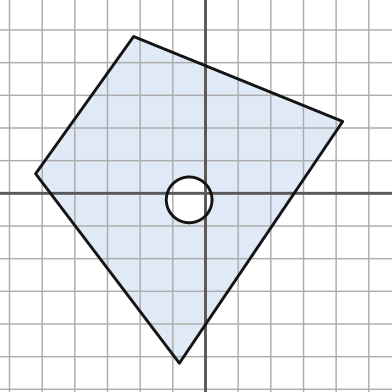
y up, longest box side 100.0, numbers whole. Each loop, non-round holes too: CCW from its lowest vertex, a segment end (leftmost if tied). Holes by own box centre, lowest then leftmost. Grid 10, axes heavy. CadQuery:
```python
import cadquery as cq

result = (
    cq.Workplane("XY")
    .moveTo(-8.0, -52.0)
    .lineTo(42.0, 22.0)
    .lineTo(-22.0, 48.0)
    .lineTo(-52.0, 6.0)
    .close()
    .moveTo(-5.0, -2.0)
    .circle(7.0)
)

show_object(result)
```